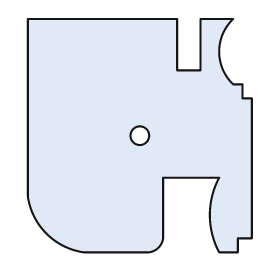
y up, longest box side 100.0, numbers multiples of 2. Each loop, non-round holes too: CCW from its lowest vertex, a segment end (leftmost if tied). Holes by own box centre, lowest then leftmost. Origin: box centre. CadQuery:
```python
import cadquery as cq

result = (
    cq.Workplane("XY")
    .moveTo(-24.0, -50.0)
    .lineTo(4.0, -50.0)
    .threePointArc((8.0, -48.0), (10.0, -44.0))
    .lineTo(10.0, -18.0)
    .lineTo(34.0, -18.0)
    .threePointArc((30.0, -34.0), (34.0, -50.0))
    .lineTo(42.0, -50.0)
    .lineTo(42.0, -44.0)
    .lineTo(48.0, -44.0)
    .lineTo(48.0, 16.0)
    .lineTo(44.0, 16.0)
    .lineTo(44.0, 22.0)
    .lineTo(40.0, 22.0)
    .threePointArc((34.0, 36.0), (40.0, 50.0))
    .lineTo(26.0, 50.0)
    .lineTo(26.0, 28.0)
    .lineTo(16.0, 28.0)
    .lineTo(16.0, 50.0)
    .lineTo(-48.0, 50.0)
    .lineTo(-48.0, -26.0)
    .threePointArc((-40.0, -42.0), (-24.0, -50.0))
    .close()
    .moveTo(0.0, 0.0)
    .circle(4.0)
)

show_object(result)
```